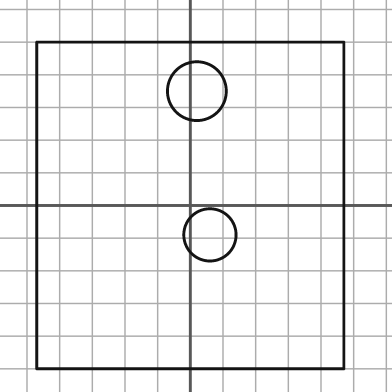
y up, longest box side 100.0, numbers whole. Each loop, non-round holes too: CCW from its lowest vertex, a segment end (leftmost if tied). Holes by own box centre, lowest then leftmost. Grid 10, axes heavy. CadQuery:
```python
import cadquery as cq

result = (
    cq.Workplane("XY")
    .moveTo(-47.0, -50.0)
    .lineTo(47.0, -50.0)
    .lineTo(47.0, 50.0)
    .lineTo(-47.0, 50.0)
    .close()
    .moveTo(6.0, -9.0)
    .circle(8.0)
    .moveTo(2.0, 35.0)
    .circle(9.0)
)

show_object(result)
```